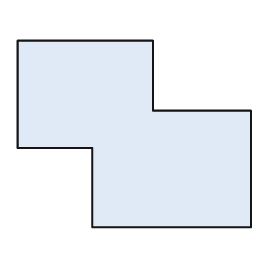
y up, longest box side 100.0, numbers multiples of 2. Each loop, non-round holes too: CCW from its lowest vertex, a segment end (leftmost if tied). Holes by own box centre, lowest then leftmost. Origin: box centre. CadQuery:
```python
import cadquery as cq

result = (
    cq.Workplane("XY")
    .moveTo(-18.0, -40.0)
    .lineTo(50.0, -40.0)
    .lineTo(50.0, 10.0)
    .lineTo(8.0, 10.0)
    .lineTo(8.0, 40.0)
    .lineTo(-50.0, 40.0)
    .lineTo(-50.0, -6.0)
    .lineTo(-18.0, -6.0)
    .close()
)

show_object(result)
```